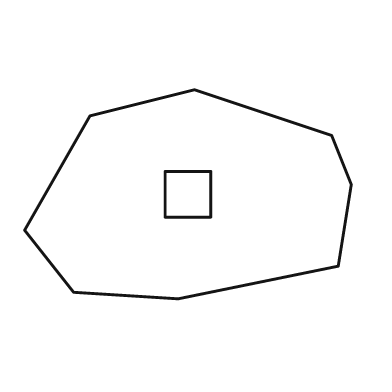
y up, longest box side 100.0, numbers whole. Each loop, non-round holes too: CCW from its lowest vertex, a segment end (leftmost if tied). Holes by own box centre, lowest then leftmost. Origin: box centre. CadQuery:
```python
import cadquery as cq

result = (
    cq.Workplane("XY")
    .moveTo(-3.0, -32.0)
    .lineTo(46.0, -22.0)
    .lineTo(50.0, 3.0)
    .lineTo(44.0, 18.0)
    .lineTo(2.0, 32.0)
    .lineTo(-30.0, 24.0)
    .lineTo(-50.0, -11.0)
    .lineTo(-35.0, -30.0)
    .close()
    .moveTo(-7.0, -7.0)
    .lineTo(7.0, -7.0)
    .lineTo(7.0, 7.0)
    .lineTo(-7.0, 7.0)
    .close()
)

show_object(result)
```